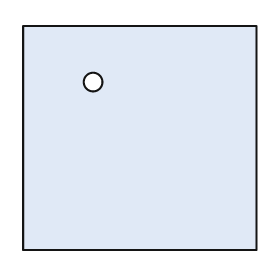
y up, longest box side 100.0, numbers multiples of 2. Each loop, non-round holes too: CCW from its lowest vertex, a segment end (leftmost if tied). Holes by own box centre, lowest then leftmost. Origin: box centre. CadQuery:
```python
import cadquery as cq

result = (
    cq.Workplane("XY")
    .moveTo(-50.0, -48.0)
    .lineTo(50.0, -48.0)
    .lineTo(50.0, 48.0)
    .lineTo(-50.0, 48.0)
    .close()
    .moveTo(-20.0, 24.0)
    .circle(4.0)
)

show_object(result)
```